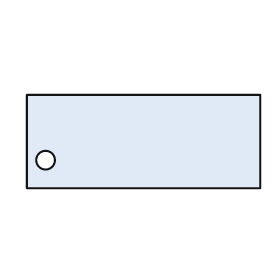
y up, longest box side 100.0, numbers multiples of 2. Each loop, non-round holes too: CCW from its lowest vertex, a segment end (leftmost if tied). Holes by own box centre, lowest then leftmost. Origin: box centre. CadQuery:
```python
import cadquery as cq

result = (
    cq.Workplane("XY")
    .moveTo(-50.0, -20.0)
    .lineTo(50.0, -20.0)
    .lineTo(50.0, 20.0)
    .lineTo(-50.0, 20.0)
    .close()
    .moveTo(-42.0, -8.0)
    .circle(4.0)
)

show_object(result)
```